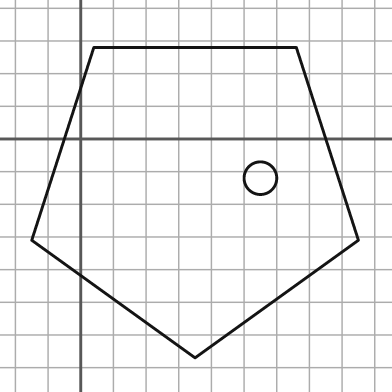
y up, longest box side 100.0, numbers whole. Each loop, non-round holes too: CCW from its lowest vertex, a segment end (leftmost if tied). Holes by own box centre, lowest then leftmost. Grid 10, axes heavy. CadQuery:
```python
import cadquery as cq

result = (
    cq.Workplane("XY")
    .moveTo(35.0, -67.0)
    .lineTo(85.0, -31.0)
    .lineTo(66.0, 28.0)
    .lineTo(4.0, 28.0)
    .lineTo(-15.0, -31.0)
    .close()
    .moveTo(55.0, -12.0)
    .circle(5.0)
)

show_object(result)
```